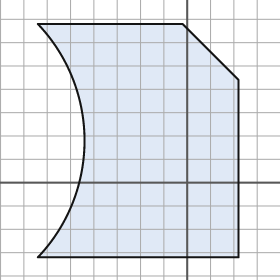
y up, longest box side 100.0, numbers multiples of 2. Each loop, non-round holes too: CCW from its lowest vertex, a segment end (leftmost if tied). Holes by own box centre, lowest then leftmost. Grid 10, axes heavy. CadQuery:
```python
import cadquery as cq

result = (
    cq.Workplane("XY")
    .moveTo(-64.0, -32.0)
    .lineTo(22.0, -32.0)
    .lineTo(22.0, 44.0)
    .lineTo(-2.0, 68.0)
    .lineTo(-64.0, 68.0)
    .threePointArc((-44.0, 18.0), (-64.0, -32.0))
    .close()
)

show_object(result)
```